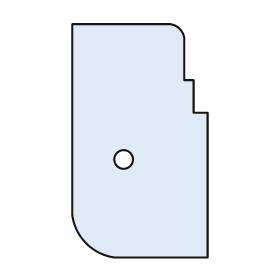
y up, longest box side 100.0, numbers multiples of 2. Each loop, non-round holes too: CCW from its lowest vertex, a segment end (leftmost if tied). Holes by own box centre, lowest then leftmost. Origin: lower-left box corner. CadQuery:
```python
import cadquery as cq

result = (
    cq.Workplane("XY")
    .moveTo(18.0, 0.0)
    .lineTo(58.0, 0.0)
    .lineTo(58.0, 62.0)
    .lineTo(52.0, 62.0)
    .lineTo(52.0, 76.0)
    .lineTo(48.0, 76.0)
    .lineTo(48.0, 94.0)
    .threePointArc((46.0, 98.0), (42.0, 100.0))
    .lineTo(0.0, 100.0)
    .lineTo(0.0, 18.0)
    .threePointArc((6.0, 6.0), (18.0, 0.0))
    .close()
    .moveTo(22.0, 42.0)
    .circle(4.0)
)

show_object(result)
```